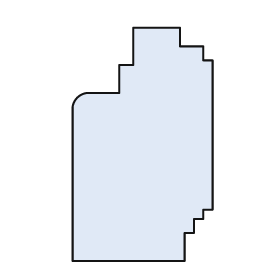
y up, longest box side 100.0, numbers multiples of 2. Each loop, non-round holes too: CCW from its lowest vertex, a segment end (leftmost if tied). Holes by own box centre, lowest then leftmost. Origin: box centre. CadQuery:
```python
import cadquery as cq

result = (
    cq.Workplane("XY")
    .moveTo(-30.0, -50.0)
    .lineTo(18.0, -50.0)
    .lineTo(18.0, -38.0)
    .lineTo(22.0, -38.0)
    .lineTo(22.0, -32.0)
    .lineTo(26.0, -32.0)
    .lineTo(26.0, -28.0)
    .lineTo(30.0, -28.0)
    .lineTo(30.0, 36.0)
    .lineTo(26.0, 36.0)
    .lineTo(26.0, 42.0)
    .lineTo(16.0, 42.0)
    .lineTo(16.0, 50.0)
    .lineTo(-4.0, 50.0)
    .lineTo(-4.0, 34.0)
    .lineTo(-10.0, 34.0)
    .lineTo(-10.0, 22.0)
    .lineTo(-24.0, 22.0)
    .threePointArc((-28.0, 20.0), (-30.0, 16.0))
    .close()
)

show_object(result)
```